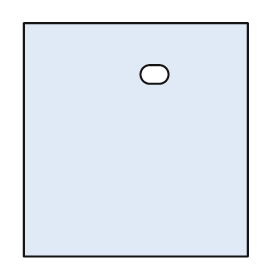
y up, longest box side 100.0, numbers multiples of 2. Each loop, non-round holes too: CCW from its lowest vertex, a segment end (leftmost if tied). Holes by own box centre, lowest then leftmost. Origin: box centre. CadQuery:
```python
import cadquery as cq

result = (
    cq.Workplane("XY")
    .moveTo(-48.0, -50.0)
    .lineTo(48.0, -50.0)
    .lineTo(48.0, 50.0)
    .lineTo(-48.0, 50.0)
    .close()
    .moveTo(6.0, 24.0)
    .lineTo(10.0, 24.0)
    .threePointArc((14.0, 28.0), (10.0, 32.0))
    .lineTo(6.0, 32.0)
    .threePointArc((2.0, 28.0), (6.0, 24.0))
    .close()
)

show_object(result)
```